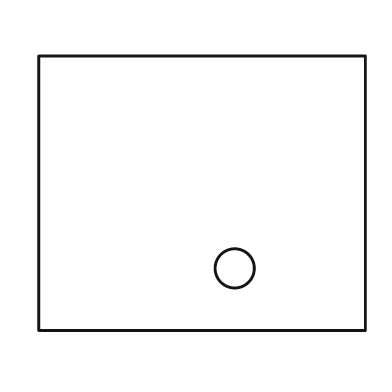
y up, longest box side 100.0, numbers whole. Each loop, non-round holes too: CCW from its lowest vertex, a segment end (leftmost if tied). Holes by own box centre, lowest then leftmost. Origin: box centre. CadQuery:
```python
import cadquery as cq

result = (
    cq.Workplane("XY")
    .moveTo(-50.0, -42.0)
    .lineTo(50.0, -42.0)
    .lineTo(50.0, 42.0)
    .lineTo(-50.0, 42.0)
    .close()
    .moveTo(10.0, -23.0)
    .circle(6.0)
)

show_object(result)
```